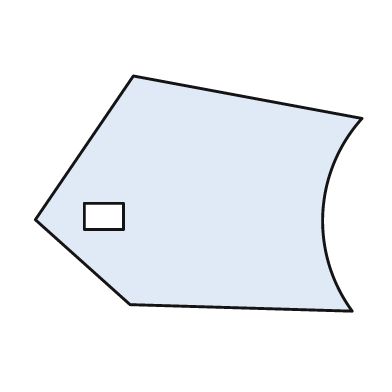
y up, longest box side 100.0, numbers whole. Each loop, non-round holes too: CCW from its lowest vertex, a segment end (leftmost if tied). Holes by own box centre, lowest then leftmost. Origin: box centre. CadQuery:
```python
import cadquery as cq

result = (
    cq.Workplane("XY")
    .moveTo(47.0, -36.0)
    .threePointArc((38.0, -6.0), (50.0, 23.0))
    .lineTo(-20.0, 36.0)
    .lineTo(-50.0, -8.0)
    .lineTo(-21.0, -34.0)
    .close()
    .moveTo(-35.0, -11.0)
    .lineTo(-23.0, -11.0)
    .lineTo(-23.0, -3.0)
    .lineTo(-35.0, -3.0)
    .close()
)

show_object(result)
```